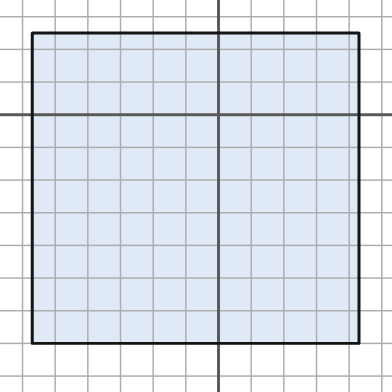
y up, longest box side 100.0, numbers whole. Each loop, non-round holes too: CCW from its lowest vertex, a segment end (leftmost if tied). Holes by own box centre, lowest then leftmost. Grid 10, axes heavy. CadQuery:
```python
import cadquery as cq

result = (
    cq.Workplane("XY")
    .moveTo(-57.0, -70.0)
    .lineTo(43.0, -70.0)
    .lineTo(43.0, 25.0)
    .lineTo(-57.0, 25.0)
    .close()
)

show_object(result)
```